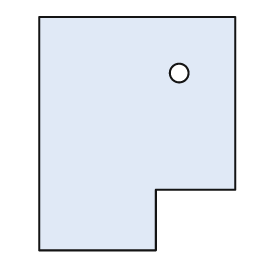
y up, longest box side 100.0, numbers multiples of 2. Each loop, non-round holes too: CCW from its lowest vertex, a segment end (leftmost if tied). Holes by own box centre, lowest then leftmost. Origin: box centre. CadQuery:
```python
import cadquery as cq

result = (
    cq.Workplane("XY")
    .moveTo(-42.0, -50.0)
    .lineTo(8.0, -50.0)
    .lineTo(8.0, -24.0)
    .lineTo(42.0, -24.0)
    .lineTo(42.0, 50.0)
    .lineTo(-42.0, 50.0)
    .close()
    .moveTo(18.0, 26.0)
    .circle(4.0)
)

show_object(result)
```